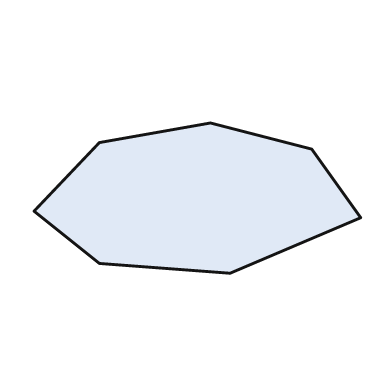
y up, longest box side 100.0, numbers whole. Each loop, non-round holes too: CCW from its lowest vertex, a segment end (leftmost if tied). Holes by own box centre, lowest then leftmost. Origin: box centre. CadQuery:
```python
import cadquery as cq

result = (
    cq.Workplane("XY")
    .moveTo(10.0, -23.0)
    .lineTo(50.0, -6.0)
    .lineTo(35.0, 15.0)
    .lineTo(4.0, 23.0)
    .lineTo(-30.0, 17.0)
    .lineTo(-50.0, -4.0)
    .lineTo(-30.0, -20.0)
    .close()
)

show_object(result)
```